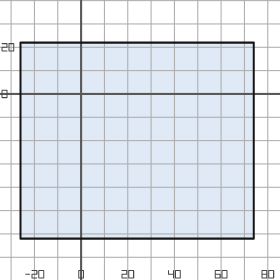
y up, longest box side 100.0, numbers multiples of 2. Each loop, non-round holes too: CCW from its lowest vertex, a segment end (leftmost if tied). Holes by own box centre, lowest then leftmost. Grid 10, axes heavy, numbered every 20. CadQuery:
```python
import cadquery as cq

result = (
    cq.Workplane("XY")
    .moveTo(-26.0, -62.0)
    .lineTo(74.0, -62.0)
    .lineTo(74.0, 22.0)
    .lineTo(-26.0, 22.0)
    .close()
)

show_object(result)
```